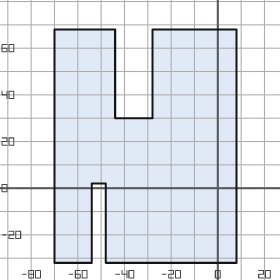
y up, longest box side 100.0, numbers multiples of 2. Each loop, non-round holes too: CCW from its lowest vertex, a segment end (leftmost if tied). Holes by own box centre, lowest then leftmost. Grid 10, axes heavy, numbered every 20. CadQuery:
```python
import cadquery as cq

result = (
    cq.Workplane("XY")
    .moveTo(-70.0, -32.0)
    .lineTo(-54.0, -32.0)
    .lineTo(-54.0, 2.0)
    .lineTo(-48.0, 2.0)
    .lineTo(-48.0, -32.0)
    .lineTo(8.0, -32.0)
    .lineTo(8.0, 68.0)
    .lineTo(-28.0, 68.0)
    .lineTo(-28.0, 30.0)
    .lineTo(-44.0, 30.0)
    .lineTo(-44.0, 68.0)
    .lineTo(-70.0, 68.0)
    .close()
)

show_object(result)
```